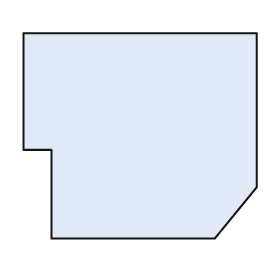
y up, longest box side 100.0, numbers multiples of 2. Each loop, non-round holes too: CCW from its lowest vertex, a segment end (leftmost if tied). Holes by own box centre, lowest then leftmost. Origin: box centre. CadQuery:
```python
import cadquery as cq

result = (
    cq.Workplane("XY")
    .moveTo(-38.0, -44.0)
    .lineTo(32.0, -44.0)
    .lineTo(50.0, -22.0)
    .lineTo(50.0, 44.0)
    .lineTo(-50.0, 44.0)
    .lineTo(-50.0, -6.0)
    .lineTo(-38.0, -6.0)
    .close()
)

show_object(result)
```